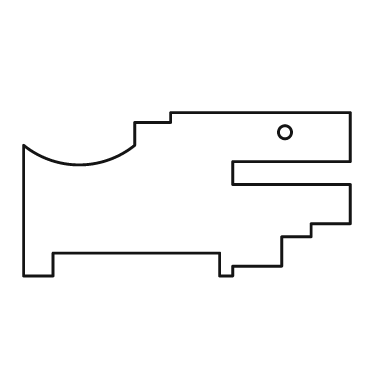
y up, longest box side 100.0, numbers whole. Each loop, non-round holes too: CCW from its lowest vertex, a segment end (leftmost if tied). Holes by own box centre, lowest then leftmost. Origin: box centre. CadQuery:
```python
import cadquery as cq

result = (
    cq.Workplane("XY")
    .moveTo(-50.0, -25.0)
    .lineTo(-41.0, -25.0)
    .lineTo(-41.0, -18.0)
    .lineTo(10.0, -18.0)
    .lineTo(10.0, -25.0)
    .lineTo(14.0, -25.0)
    .lineTo(14.0, -22.0)
    .lineTo(29.0, -22.0)
    .lineTo(29.0, -13.0)
    .lineTo(38.0, -13.0)
    .lineTo(38.0, -9.0)
    .lineTo(50.0, -9.0)
    .lineTo(50.0, 3.0)
    .lineTo(14.0, 3.0)
    .lineTo(14.0, 10.0)
    .lineTo(50.0, 10.0)
    .lineTo(50.0, 25.0)
    .lineTo(-5.0, 25.0)
    .lineTo(-5.0, 22.0)
    .lineTo(-16.0, 22.0)
    .lineTo(-16.0, 15.0)
    .threePointArc((-33.0, 9.0), (-50.0, 15.0))
    .close()
    .moveTo(30.0, 19.0)
    .circle(2.0)
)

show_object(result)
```